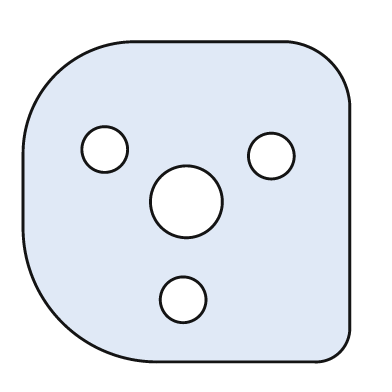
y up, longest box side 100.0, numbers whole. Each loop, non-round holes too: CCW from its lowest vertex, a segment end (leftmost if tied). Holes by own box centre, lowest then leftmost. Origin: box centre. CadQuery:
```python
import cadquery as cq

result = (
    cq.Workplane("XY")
    .moveTo(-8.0, -49.0)
    .lineTo(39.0, -49.0)
    .threePointArc((47.0, -46.0), (50.0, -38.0))
    .lineTo(50.0, 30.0)
    .threePointArc((44.0, 43.0), (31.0, 49.0))
    .lineTo(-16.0, 49.0)
    .threePointArc((-40.0, 39.0), (-50.0, 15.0))
    .lineTo(-50.0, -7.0)
    .threePointArc((-38.0, -37.0), (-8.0, -49.0))
    .close()
    .moveTo(-1.0, -30.0)
    .circle(7.0)
    .moveTo(0.0, 0.0)
    .circle(11.0)
    .moveTo(26.0, 14.0)
    .circle(7.0)
    .moveTo(-25.0, 16.0)
    .circle(7.0)
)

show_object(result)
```